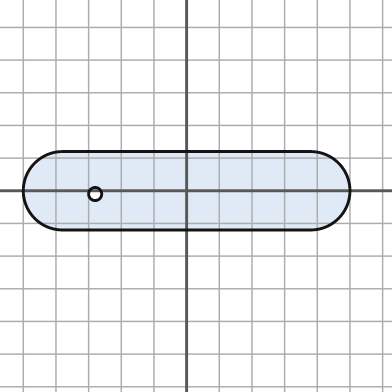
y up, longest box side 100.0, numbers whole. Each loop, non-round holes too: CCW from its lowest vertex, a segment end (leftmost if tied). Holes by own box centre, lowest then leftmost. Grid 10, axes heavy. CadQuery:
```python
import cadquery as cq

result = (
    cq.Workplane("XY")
    .moveTo(-38.0, -12.0)
    .lineTo(38.0, -12.0)
    .threePointArc((50.0, 0.0), (38.0, 12.0))
    .lineTo(-38.0, 12.0)
    .threePointArc((-50.0, 0.0), (-38.0, -12.0))
    .close()
    .moveTo(-28.0, -1.0)
    .circle(2.0)
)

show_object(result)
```